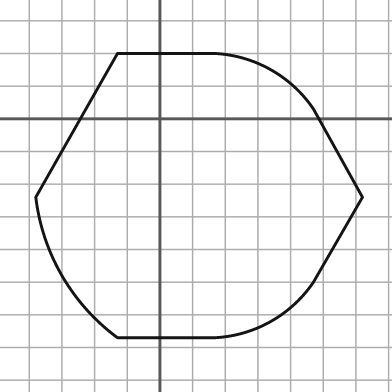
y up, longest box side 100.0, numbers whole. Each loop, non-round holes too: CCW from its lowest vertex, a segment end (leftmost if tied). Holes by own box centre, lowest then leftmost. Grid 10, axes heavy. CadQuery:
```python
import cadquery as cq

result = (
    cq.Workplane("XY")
    .moveTo(-13.0, -67.0)
    .lineTo(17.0, -67.0)
    .threePointArc((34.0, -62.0), (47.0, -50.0))
    .lineTo(62.0, -24.0)
    .lineTo(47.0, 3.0)
    .threePointArc((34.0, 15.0), (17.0, 20.0))
    .lineTo(-13.0, 20.0)
    .lineTo(-38.0, -24.0)
    .threePointArc((-30.0, -48.0), (-13.0, -67.0))
    .close()
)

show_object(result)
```